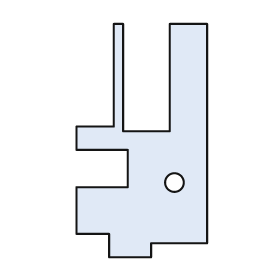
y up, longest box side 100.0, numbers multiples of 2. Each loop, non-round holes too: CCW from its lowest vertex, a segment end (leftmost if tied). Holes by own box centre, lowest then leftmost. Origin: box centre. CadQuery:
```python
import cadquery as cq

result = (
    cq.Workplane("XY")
    .moveTo(-14.0, -50.0)
    .lineTo(4.0, -50.0)
    .lineTo(4.0, -44.0)
    .lineTo(28.0, -44.0)
    .lineTo(28.0, 50.0)
    .lineTo(12.0, 50.0)
    .lineTo(12.0, 4.0)
    .lineTo(-8.0, 4.0)
    .lineTo(-8.0, 50.0)
    .lineTo(-12.0, 50.0)
    .lineTo(-12.0, 6.0)
    .lineTo(-28.0, 6.0)
    .lineTo(-28.0, -4.0)
    .lineTo(-6.0, -4.0)
    .lineTo(-6.0, -20.0)
    .lineTo(-28.0, -20.0)
    .lineTo(-28.0, -40.0)
    .lineTo(-14.0, -40.0)
    .close()
    .moveTo(14.0, -18.0)
    .circle(4.0)
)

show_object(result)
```